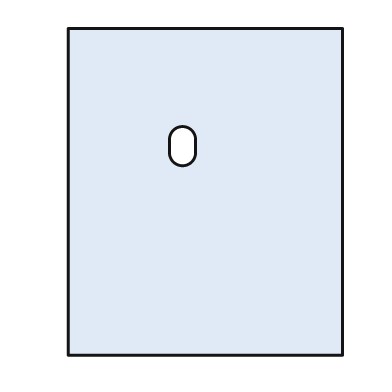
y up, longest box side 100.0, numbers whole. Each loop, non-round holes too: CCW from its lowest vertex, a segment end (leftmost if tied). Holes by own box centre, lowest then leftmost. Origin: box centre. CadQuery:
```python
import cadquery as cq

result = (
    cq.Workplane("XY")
    .moveTo(-42.0, -50.0)
    .lineTo(42.0, -50.0)
    .lineTo(42.0, 50.0)
    .lineTo(-42.0, 50.0)
    .close()
    .moveTo(-11.0, 12.0)
    .threePointArc((-7.0, 8.0), (-3.0, 12.0))
    .lineTo(-3.0, 16.0)
    .threePointArc((-7.0, 20.0), (-11.0, 16.0))
    .close()
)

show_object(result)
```